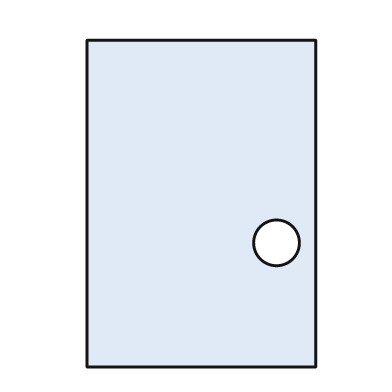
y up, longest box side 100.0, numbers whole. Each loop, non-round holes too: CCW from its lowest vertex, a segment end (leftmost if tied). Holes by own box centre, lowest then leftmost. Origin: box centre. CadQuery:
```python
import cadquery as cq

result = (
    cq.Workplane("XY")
    .moveTo(-35.0, -50.0)
    .lineTo(35.0, -50.0)
    .lineTo(35.0, 50.0)
    .lineTo(-35.0, 50.0)
    .close()
    .moveTo(23.0, -12.0)
    .circle(7.0)
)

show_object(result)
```